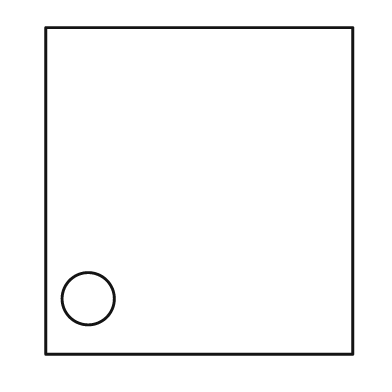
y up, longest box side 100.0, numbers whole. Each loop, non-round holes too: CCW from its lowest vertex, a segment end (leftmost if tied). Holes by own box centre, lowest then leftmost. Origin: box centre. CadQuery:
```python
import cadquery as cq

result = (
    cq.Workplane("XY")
    .moveTo(-47.0, -50.0)
    .lineTo(47.0, -50.0)
    .lineTo(47.0, 50.0)
    .lineTo(-47.0, 50.0)
    .close()
    .moveTo(-34.0, -33.0)
    .circle(8.0)
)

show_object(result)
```